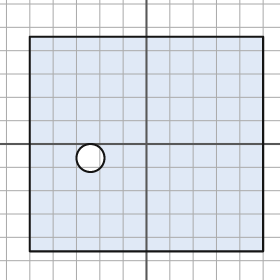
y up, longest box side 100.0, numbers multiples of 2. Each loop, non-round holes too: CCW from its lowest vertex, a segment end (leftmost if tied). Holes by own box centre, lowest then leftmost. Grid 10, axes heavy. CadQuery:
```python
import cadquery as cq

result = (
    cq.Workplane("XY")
    .moveTo(-50.0, -46.0)
    .lineTo(50.0, -46.0)
    .lineTo(50.0, 46.0)
    .lineTo(-50.0, 46.0)
    .close()
    .moveTo(-24.0, -6.0)
    .circle(6.0)
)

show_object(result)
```